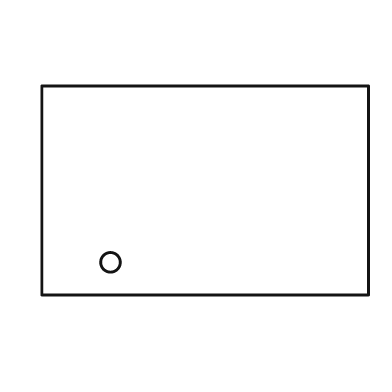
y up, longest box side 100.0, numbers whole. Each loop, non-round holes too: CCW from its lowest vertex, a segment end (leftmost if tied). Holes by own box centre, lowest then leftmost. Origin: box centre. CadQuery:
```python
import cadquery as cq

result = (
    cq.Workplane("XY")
    .moveTo(-50.0, -32.0)
    .lineTo(50.0, -32.0)
    .lineTo(50.0, 32.0)
    .lineTo(-50.0, 32.0)
    .close()
    .moveTo(-29.0, -22.0)
    .circle(3.0)
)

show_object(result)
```